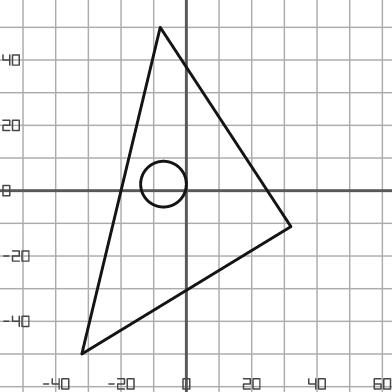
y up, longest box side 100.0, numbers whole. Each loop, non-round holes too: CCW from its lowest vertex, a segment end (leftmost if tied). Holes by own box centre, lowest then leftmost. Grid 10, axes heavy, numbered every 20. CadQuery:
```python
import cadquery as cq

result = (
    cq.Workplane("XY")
    .moveTo(-32.0, -50.0)
    .lineTo(32.0, -11.0)
    .lineTo(-8.0, 50.0)
    .close()
    .moveTo(-7.0, 2.0)
    .circle(7.0)
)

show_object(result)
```